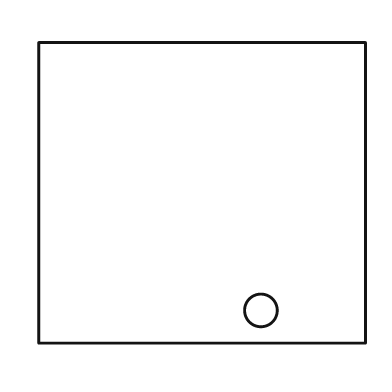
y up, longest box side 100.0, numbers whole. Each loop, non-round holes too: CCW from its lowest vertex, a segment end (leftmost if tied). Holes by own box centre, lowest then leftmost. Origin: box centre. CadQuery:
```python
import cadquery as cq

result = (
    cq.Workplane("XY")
    .moveTo(-50.0, -46.0)
    .lineTo(50.0, -46.0)
    .lineTo(50.0, 46.0)
    .lineTo(-50.0, 46.0)
    .close()
    .moveTo(18.0, -36.0)
    .circle(5.0)
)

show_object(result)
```